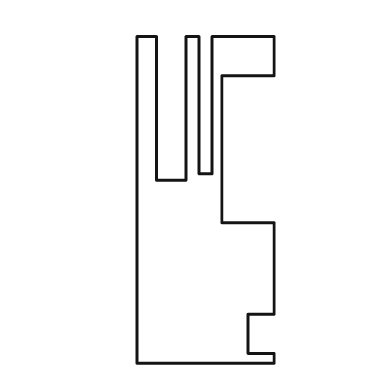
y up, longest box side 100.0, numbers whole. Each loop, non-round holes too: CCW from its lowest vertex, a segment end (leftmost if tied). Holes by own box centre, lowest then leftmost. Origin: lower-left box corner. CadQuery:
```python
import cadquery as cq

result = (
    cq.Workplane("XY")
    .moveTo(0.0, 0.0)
    .lineTo(42.0, 0.0)
    .lineTo(42.0, 3.0)
    .lineTo(34.0, 3.0)
    .lineTo(34.0, 15.0)
    .lineTo(42.0, 15.0)
    .lineTo(42.0, 43.0)
    .lineTo(26.0, 43.0)
    .lineTo(26.0, 88.0)
    .lineTo(42.0, 88.0)
    .lineTo(42.0, 100.0)
    .lineTo(23.0, 100.0)
    .lineTo(23.0, 58.0)
    .lineTo(19.0, 58.0)
    .lineTo(19.0, 100.0)
    .lineTo(15.0, 100.0)
    .lineTo(15.0, 56.0)
    .lineTo(6.0, 56.0)
    .lineTo(6.0, 100.0)
    .lineTo(0.0, 100.0)
    .close()
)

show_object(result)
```